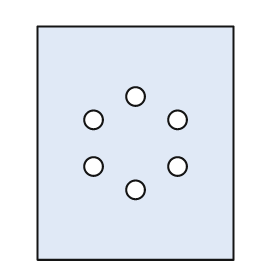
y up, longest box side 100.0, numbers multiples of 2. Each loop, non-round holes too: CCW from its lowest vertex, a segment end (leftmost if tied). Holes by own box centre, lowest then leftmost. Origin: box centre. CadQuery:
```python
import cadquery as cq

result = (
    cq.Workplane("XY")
    .moveTo(-42.0, -50.0)
    .lineTo(42.0, -50.0)
    .lineTo(42.0, 50.0)
    .lineTo(-42.0, 50.0)
    .close()
    .moveTo(0.0, -20.0)
    .circle(4.0)
    .moveTo(-18.0, -10.0)
    .circle(4.0)
    .moveTo(18.0, -10.0)
    .circle(4.0)
    .moveTo(-18.0, 10.0)
    .circle(4.0)
    .moveTo(18.0, 10.0)
    .circle(4.0)
    .moveTo(0.0, 20.0)
    .circle(4.0)
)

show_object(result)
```